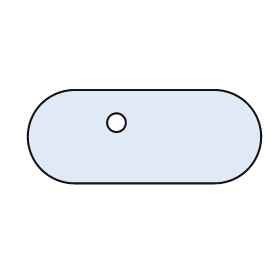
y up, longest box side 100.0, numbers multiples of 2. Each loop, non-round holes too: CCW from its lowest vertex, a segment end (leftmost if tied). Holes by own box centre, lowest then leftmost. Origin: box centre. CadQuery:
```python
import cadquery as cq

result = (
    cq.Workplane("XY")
    .moveTo(-30.0, -20.0)
    .lineTo(30.0, -20.0)
    .threePointArc((50.0, 0.0), (30.0, 20.0))
    .lineTo(-30.0, 20.0)
    .threePointArc((-50.0, 0.0), (-30.0, -20.0))
    .close()
    .moveTo(-12.0, 6.0)
    .circle(4.0)
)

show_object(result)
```